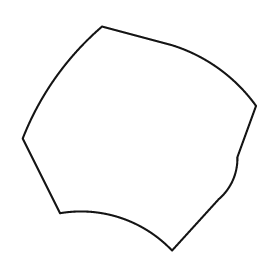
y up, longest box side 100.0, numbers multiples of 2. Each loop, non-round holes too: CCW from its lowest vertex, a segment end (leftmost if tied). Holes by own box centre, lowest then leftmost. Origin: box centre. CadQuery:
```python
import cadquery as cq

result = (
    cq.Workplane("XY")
    .moveTo(14.0, -48.0)
    .lineTo(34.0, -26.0)
    .threePointArc((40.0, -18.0), (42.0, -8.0))
    .lineTo(50.0, 14.0)
    .threePointArc((34.0, 30.0), (14.0, 40.0))
    .lineTo(-16.0, 48.0)
    .threePointArc((-36.0, 26.0), (-50.0, 0.0))
    .lineTo(-34.0, -32.0)
    .threePointArc((-8.0, -34.0), (14.0, -48.0))
    .close()
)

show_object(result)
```